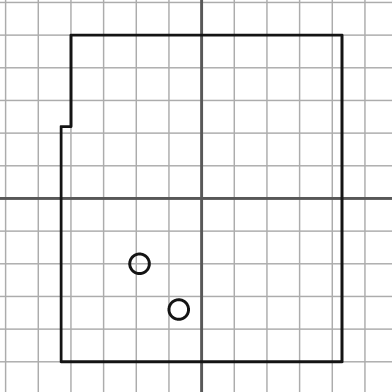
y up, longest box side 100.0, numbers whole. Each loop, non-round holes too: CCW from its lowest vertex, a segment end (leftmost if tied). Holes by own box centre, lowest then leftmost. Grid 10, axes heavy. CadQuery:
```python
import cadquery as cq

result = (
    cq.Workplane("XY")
    .moveTo(-43.0, -50.0)
    .lineTo(43.0, -50.0)
    .lineTo(43.0, 50.0)
    .lineTo(-40.0, 50.0)
    .lineTo(-40.0, 22.0)
    .lineTo(-43.0, 22.0)
    .close()
    .moveTo(-7.0, -34.0)
    .circle(3.0)
    .moveTo(-19.0, -20.0)
    .circle(3.0)
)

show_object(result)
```